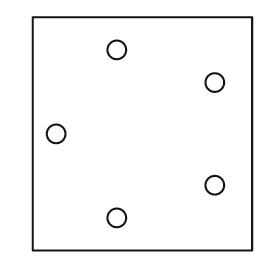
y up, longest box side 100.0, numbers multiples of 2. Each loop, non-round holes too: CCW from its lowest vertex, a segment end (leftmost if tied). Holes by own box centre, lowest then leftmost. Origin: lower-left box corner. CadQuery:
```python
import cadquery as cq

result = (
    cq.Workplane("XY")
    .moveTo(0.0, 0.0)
    .lineTo(94.0, 0.0)
    .lineTo(94.0, 100.0)
    .lineTo(0.0, 100.0)
    .close()
    .moveTo(36.0, 14.0)
    .circle(4.0)
    .moveTo(78.0, 28.0)
    .circle(4.0)
    .moveTo(10.0, 50.0)
    .circle(4.0)
    .moveTo(78.0, 72.0)
    .circle(4.0)
    .moveTo(36.0, 86.0)
    .circle(4.0)
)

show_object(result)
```